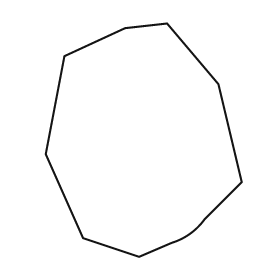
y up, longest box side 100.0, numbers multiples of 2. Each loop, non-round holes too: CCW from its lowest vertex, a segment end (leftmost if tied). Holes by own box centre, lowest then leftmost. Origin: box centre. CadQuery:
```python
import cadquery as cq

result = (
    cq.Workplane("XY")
    .moveTo(-2.0, -50.0)
    .lineTo(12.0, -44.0)
    .threePointArc((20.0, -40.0), (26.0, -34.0))
    .lineTo(42.0, -18.0)
    .lineTo(32.0, 24.0)
    .lineTo(10.0, 50.0)
    .lineTo(-8.0, 48.0)
    .lineTo(-34.0, 36.0)
    .lineTo(-42.0, -6.0)
    .lineTo(-26.0, -42.0)
    .close()
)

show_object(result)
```